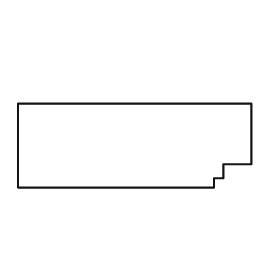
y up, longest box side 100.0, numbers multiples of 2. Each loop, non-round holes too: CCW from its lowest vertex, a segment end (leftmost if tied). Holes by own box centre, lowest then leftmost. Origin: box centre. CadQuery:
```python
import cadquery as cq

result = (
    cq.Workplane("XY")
    .moveTo(-50.0, -18.0)
    .lineTo(34.0, -18.0)
    .lineTo(34.0, -14.0)
    .lineTo(38.0, -14.0)
    .lineTo(38.0, -8.0)
    .lineTo(50.0, -8.0)
    .lineTo(50.0, 18.0)
    .lineTo(-50.0, 18.0)
    .close()
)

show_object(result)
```